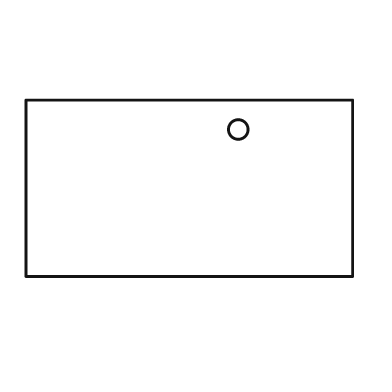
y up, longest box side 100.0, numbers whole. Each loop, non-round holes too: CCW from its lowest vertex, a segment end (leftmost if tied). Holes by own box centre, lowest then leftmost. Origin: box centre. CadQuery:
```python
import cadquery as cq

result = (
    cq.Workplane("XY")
    .moveTo(-50.0, -27.0)
    .lineTo(50.0, -27.0)
    .lineTo(50.0, 27.0)
    .lineTo(-50.0, 27.0)
    .close()
    .moveTo(15.0, 18.0)
    .circle(3.0)
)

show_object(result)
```